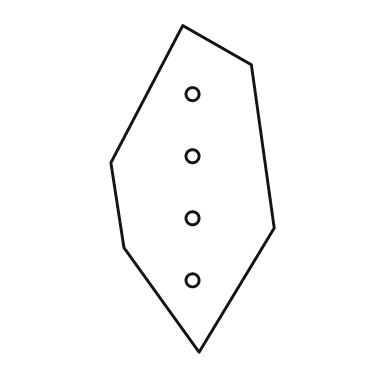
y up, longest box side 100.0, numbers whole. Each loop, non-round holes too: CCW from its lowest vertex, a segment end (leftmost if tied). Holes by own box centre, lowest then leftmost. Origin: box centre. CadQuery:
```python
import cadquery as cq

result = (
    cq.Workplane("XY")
    .moveTo(2.0, -50.0)
    .lineTo(25.0, -12.0)
    .lineTo(18.0, 38.0)
    .lineTo(-3.0, 50.0)
    .lineTo(-25.0, 8.0)
    .lineTo(-21.0, -18.0)
    .close()
    .moveTo(0.0, -28.0)
    .circle(2.0)
    .moveTo(0.0, -9.0)
    .circle(2.0)
    .moveTo(0.0, 10.0)
    .circle(2.0)
    .moveTo(0.0, 29.0)
    .circle(2.0)
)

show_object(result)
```